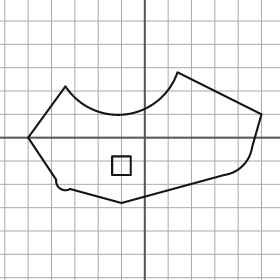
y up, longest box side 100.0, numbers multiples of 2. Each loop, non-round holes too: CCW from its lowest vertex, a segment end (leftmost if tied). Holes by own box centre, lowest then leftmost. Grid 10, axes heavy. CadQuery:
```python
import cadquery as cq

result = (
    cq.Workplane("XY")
    .moveTo(-10.0, -28.0)
    .lineTo(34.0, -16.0)
    .threePointArc((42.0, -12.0), (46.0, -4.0))
    .lineTo(50.0, 10.0)
    .lineTo(14.0, 28.0)
    .threePointArc((-8.0, 10.0), (-34.0, 22.0))
    .lineTo(-50.0, 0.0)
    .lineTo(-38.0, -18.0)
    .threePointArc((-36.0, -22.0), (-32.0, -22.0))
    .close()
    .moveTo(-14.0, -16.0)
    .lineTo(-6.0, -16.0)
    .lineTo(-6.0, -8.0)
    .lineTo(-14.0, -8.0)
    .close()
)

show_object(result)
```